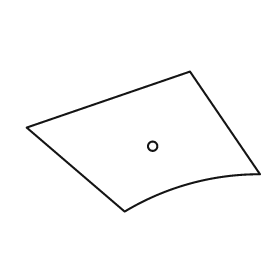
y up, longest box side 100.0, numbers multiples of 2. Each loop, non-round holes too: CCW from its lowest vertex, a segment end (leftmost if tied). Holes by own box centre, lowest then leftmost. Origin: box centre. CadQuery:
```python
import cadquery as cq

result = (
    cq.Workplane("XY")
    .moveTo(-8.0, -30.0)
    .threePointArc((20.0, -18.0), (50.0, -14.0))
    .lineTo(20.0, 30.0)
    .lineTo(-50.0, 6.0)
    .close()
    .moveTo(4.0, -2.0)
    .circle(2.0)
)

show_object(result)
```